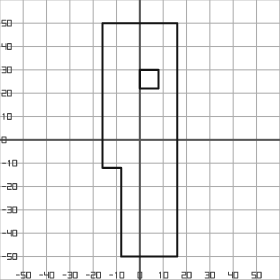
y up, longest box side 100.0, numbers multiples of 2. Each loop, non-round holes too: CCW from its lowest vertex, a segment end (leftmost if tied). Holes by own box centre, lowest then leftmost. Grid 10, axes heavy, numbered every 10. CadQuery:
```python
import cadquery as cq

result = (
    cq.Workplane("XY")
    .moveTo(-8.0, -50.0)
    .lineTo(16.0, -50.0)
    .lineTo(16.0, 50.0)
    .lineTo(-16.0, 50.0)
    .lineTo(-16.0, -12.0)
    .lineTo(-8.0, -12.0)
    .close()
    .moveTo(0.0, 22.0)
    .lineTo(8.0, 22.0)
    .lineTo(8.0, 30.0)
    .lineTo(0.0, 30.0)
    .close()
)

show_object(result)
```